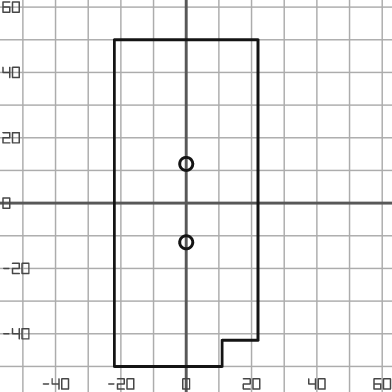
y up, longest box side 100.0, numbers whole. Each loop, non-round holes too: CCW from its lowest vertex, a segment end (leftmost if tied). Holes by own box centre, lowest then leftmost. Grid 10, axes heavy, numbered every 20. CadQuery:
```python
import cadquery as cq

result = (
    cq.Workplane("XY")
    .moveTo(-22.0, -50.0)
    .lineTo(11.0, -50.0)
    .lineTo(11.0, -42.0)
    .lineTo(22.0, -42.0)
    .lineTo(22.0, 50.0)
    .lineTo(-22.0, 50.0)
    .close()
    .moveTo(0.0, -12.0)
    .circle(2.0)
    .moveTo(0.0, 12.0)
    .circle(2.0)
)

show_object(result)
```